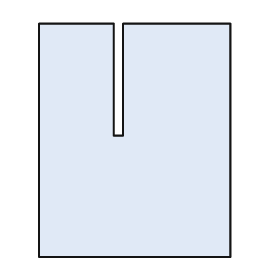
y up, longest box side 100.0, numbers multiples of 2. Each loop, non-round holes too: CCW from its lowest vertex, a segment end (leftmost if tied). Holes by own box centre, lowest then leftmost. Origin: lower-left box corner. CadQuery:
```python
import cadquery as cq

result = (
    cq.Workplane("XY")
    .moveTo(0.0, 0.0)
    .lineTo(82.0, 0.0)
    .lineTo(82.0, 100.0)
    .lineTo(36.0, 100.0)
    .lineTo(36.0, 52.0)
    .lineTo(32.0, 52.0)
    .lineTo(32.0, 100.0)
    .lineTo(0.0, 100.0)
    .close()
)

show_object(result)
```